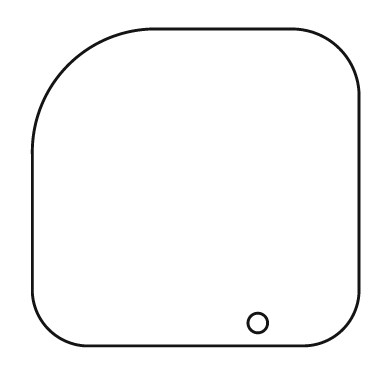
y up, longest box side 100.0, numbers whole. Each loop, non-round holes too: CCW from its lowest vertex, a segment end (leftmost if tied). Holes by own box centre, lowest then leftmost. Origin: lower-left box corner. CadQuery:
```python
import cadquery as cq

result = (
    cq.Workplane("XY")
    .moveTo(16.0, 0.0)
    .lineTo(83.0, 0.0)
    .threePointArc((95.0, 5.0), (100.0, 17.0))
    .lineTo(100.0, 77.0)
    .threePointArc((94.0, 91.0), (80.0, 97.0))
    .lineTo(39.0, 97.0)
    .threePointArc((11.0, 86.0), (0.0, 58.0))
    .lineTo(0.0, 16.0)
    .threePointArc((5.0, 5.0), (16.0, 0.0))
    .close()
    .moveTo(69.0, 7.0)
    .circle(3.0)
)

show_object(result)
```